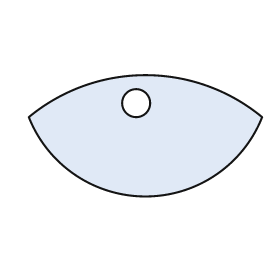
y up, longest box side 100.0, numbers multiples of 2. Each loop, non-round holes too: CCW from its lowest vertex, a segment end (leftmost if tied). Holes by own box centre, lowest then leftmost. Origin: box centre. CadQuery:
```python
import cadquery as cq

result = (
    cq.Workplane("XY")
    .moveTo(-50.0, 8.0)
    .threePointArc((0.0, -26.0), (50.0, 8.0))
    .threePointArc((0.0, 26.0), (-50.0, 8.0))
    .close()
    .moveTo(-4.0, 14.0)
    .circle(6.0)
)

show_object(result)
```